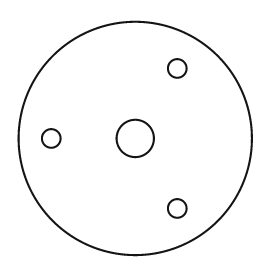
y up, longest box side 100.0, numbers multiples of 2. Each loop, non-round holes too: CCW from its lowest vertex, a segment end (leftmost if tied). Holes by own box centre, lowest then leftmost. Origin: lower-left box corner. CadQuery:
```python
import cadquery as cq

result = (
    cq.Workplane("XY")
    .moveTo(50.0, 50.0)
    .circle(50.0)
    .moveTo(68.0, 20.0)
    .circle(4.0)
    .moveTo(14.0, 50.0)
    .circle(4.0)
    .moveTo(50.0, 50.0)
    .circle(8.0)
    .moveTo(68.0, 80.0)
    .circle(4.0)
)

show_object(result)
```